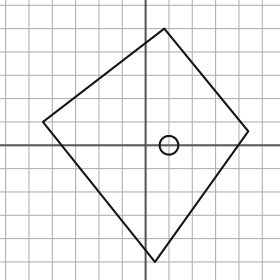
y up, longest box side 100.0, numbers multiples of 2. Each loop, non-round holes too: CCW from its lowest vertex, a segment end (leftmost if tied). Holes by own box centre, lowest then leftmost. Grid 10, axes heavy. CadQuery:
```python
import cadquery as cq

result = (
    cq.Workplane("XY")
    .moveTo(4.0, -50.0)
    .lineTo(44.0, 6.0)
    .lineTo(8.0, 50.0)
    .lineTo(-44.0, 10.0)
    .close()
    .moveTo(10.0, 0.0)
    .circle(4.0)
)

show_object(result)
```